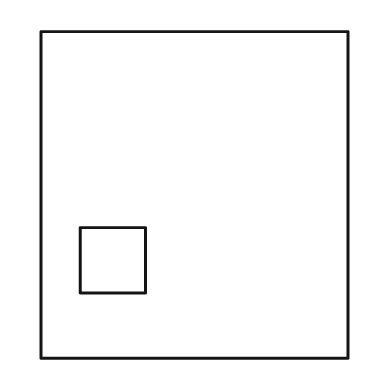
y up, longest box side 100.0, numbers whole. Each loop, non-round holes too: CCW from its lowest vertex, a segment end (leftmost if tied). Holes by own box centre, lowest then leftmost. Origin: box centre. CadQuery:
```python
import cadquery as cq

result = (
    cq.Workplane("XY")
    .moveTo(-47.0, -50.0)
    .lineTo(47.0, -50.0)
    .lineTo(47.0, 50.0)
    .lineTo(-47.0, 50.0)
    .close()
    .moveTo(-35.0, -30.0)
    .lineTo(-15.0, -30.0)
    .lineTo(-15.0, -10.0)
    .lineTo(-35.0, -10.0)
    .close()
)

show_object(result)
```